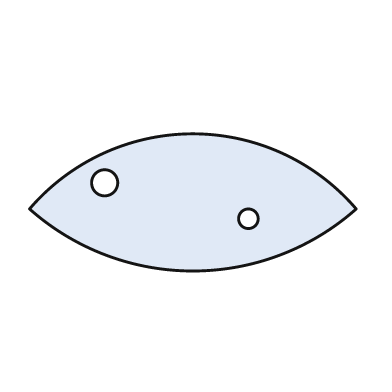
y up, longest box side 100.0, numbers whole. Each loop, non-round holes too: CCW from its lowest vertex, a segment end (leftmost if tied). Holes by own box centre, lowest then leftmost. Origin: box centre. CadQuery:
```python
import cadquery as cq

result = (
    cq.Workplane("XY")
    .moveTo(-50.0, -2.0)
    .threePointArc((0.0, -21.0), (50.0, -2.0))
    .threePointArc((0.0, 21.0), (-50.0, -2.0))
    .close()
    .moveTo(17.0, -5.0)
    .circle(3.0)
    .moveTo(-27.0, 6.0)
    .circle(4.0)
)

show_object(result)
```